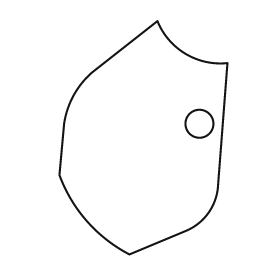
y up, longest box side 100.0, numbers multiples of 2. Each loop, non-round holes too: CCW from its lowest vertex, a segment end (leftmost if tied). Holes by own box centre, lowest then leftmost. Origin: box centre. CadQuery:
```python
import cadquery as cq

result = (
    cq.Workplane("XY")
    .moveTo(-6.0, -50.0)
    .lineTo(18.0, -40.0)
    .threePointArc((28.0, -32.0), (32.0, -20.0))
    .lineTo(36.0, 32.0)
    .threePointArc((18.0, 36.0), (6.0, 50.0))
    .lineTo(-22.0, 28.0)
    .threePointArc((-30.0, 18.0), (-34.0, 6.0))
    .lineTo(-36.0, -16.0)
    .threePointArc((-24.0, -36.0), (-6.0, -50.0))
    .close()
    .moveTo(24.0, 6.0)
    .circle(6.0)
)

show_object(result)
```